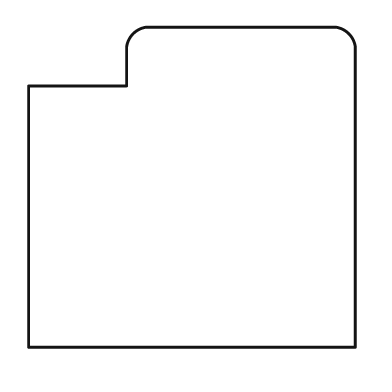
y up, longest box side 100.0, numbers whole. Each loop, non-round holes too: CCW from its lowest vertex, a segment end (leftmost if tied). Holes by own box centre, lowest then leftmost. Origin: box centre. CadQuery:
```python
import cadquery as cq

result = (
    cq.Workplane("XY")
    .moveTo(-50.0, -49.0)
    .lineTo(50.0, -49.0)
    .lineTo(50.0, 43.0)
    .threePointArc((48.0, 47.0), (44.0, 49.0))
    .lineTo(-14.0, 49.0)
    .threePointArc((-18.0, 47.0), (-20.0, 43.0))
    .lineTo(-20.0, 31.0)
    .lineTo(-50.0, 31.0)
    .close()
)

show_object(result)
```